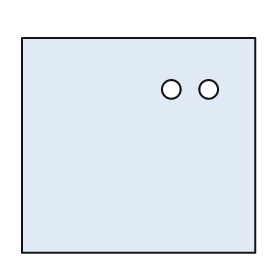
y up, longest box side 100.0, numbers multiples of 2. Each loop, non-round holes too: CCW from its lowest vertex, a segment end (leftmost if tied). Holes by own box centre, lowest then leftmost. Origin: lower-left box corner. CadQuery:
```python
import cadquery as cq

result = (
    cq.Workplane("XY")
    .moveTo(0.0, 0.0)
    .lineTo(100.0, 0.0)
    .lineTo(100.0, 92.0)
    .lineTo(0.0, 92.0)
    .close()
    .moveTo(64.0, 70.0)
    .circle(4.0)
    .moveTo(80.0, 70.0)
    .circle(4.0)
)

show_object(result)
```